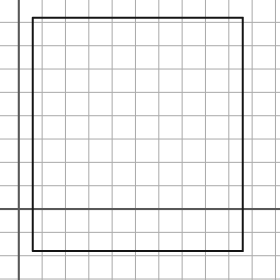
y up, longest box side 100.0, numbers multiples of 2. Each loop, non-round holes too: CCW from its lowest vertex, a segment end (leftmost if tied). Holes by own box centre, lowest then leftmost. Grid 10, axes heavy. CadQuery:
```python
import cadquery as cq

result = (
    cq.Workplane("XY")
    .moveTo(6.0, -18.0)
    .lineTo(96.0, -18.0)
    .lineTo(96.0, 82.0)
    .lineTo(6.0, 82.0)
    .close()
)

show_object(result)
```